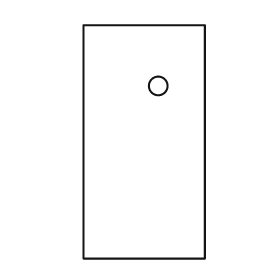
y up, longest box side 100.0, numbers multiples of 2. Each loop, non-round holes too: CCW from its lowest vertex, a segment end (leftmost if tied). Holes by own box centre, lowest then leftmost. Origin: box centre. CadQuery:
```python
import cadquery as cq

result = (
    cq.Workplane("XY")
    .moveTo(-26.0, -50.0)
    .lineTo(26.0, -50.0)
    .lineTo(26.0, 50.0)
    .lineTo(-26.0, 50.0)
    .close()
    .moveTo(6.0, 24.0)
    .circle(4.0)
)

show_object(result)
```